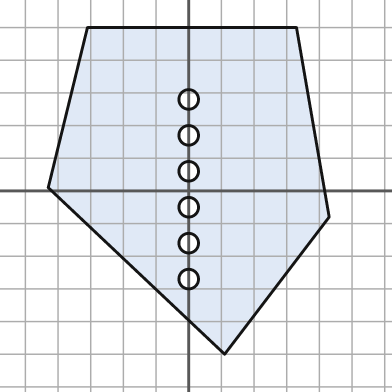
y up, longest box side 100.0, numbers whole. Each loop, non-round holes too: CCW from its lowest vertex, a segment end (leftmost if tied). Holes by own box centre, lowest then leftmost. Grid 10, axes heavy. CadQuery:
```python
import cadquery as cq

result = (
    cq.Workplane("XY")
    .moveTo(11.0, -50.0)
    .lineTo(43.0, -8.0)
    .lineTo(33.0, 50.0)
    .lineTo(-31.0, 50.0)
    .lineTo(-43.0, 1.0)
    .close()
    .moveTo(0.0, -27.0)
    .circle(3.0)
    .moveTo(0.0, -16.0)
    .circle(3.0)
    .moveTo(0.0, -5.0)
    .circle(3.0)
    .moveTo(0.0, 6.0)
    .circle(3.0)
    .moveTo(0.0, 17.0)
    .circle(3.0)
    .moveTo(0.0, 28.0)
    .circle(3.0)
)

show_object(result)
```